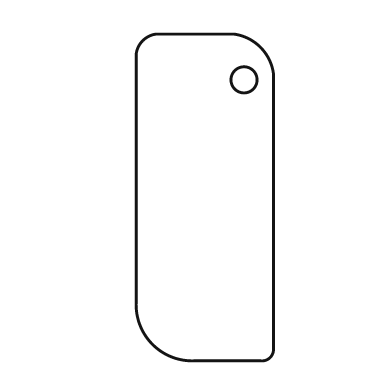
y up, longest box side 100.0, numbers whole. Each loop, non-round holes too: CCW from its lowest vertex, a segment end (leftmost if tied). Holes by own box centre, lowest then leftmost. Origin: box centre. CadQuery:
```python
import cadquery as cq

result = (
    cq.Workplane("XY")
    .moveTo(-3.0, -50.0)
    .lineTo(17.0, -50.0)
    .threePointArc((20.0, -49.0), (21.0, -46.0))
    .lineTo(21.0, 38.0)
    .threePointArc((17.0, 46.0), (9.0, 50.0))
    .lineTo(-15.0, 50.0)
    .threePointArc((-19.0, 48.0), (-21.0, 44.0))
    .lineTo(-21.0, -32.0)
    .threePointArc((-16.0, -45.0), (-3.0, -50.0))
    .close()
    .moveTo(12.0, 36.0)
    .circle(4.0)
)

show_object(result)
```